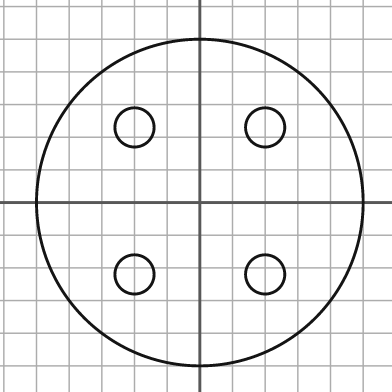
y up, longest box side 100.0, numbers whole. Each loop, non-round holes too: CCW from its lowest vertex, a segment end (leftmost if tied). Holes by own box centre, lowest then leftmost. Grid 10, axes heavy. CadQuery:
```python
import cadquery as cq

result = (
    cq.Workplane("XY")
    .moveTo(0.0, 0.0)
    .circle(50.0)
    .moveTo(-20.0, -22.0)
    .circle(6.0)
    .moveTo(20.0, -22.0)
    .circle(6.0)
    .moveTo(-20.0, 23.0)
    .circle(6.0)
    .moveTo(20.0, 23.0)
    .circle(6.0)
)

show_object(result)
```